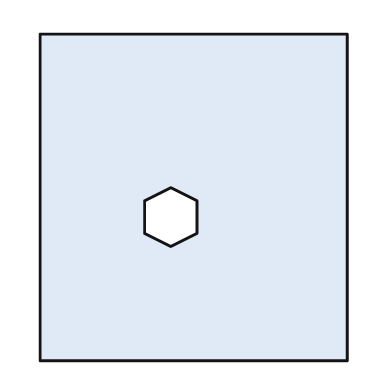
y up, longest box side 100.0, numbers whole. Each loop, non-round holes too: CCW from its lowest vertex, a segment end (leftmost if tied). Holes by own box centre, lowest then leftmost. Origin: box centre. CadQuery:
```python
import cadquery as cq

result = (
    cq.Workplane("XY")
    .moveTo(-47.0, -50.0)
    .lineTo(47.0, -50.0)
    .lineTo(47.0, 50.0)
    .lineTo(-47.0, 50.0)
    .close()
    .moveTo(-7.0, -15.0)
    .lineTo(1.0, -11.0)
    .lineTo(1.0, -1.0)
    .lineTo(-7.0, 3.0)
    .lineTo(-15.0, -1.0)
    .lineTo(-15.0, -11.0)
    .close()
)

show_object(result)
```